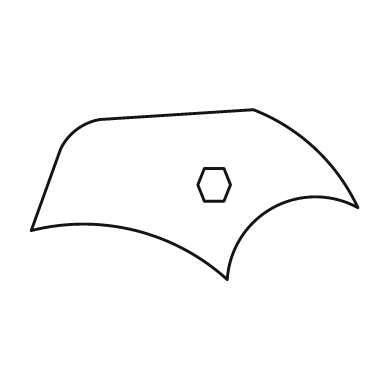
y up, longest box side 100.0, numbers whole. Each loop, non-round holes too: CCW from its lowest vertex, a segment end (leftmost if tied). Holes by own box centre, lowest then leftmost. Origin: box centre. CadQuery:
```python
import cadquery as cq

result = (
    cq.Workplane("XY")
    .moveTo(10.0, -26.0)
    .threePointArc((24.0, -4.0), (50.0, -4.0))
    .threePointArc((37.0, 14.0), (18.0, 26.0))
    .lineTo(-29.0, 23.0)
    .threePointArc((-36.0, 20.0), (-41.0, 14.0))
    .lineTo(-50.0, -11.0)
    .threePointArc((-18.0, -11.0), (10.0, -26.0))
    .close()
    .moveTo(3.0, -2.0)
    .lineTo(9.0, -2.0)
    .lineTo(11.0, 3.0)
    .lineTo(9.0, 8.0)
    .lineTo(3.0, 8.0)
    .lineTo(1.0, 3.0)
    .close()
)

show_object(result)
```